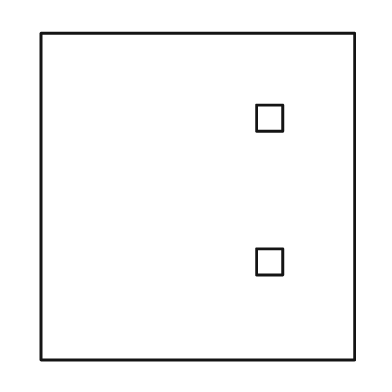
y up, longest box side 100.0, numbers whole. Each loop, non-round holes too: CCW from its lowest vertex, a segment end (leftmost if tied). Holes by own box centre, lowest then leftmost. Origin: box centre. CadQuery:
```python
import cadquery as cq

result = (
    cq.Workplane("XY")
    .moveTo(-48.0, -50.0)
    .lineTo(48.0, -50.0)
    .lineTo(48.0, 50.0)
    .lineTo(-48.0, 50.0)
    .close()
    .moveTo(18.0, -24.0)
    .lineTo(26.0, -24.0)
    .lineTo(26.0, -16.0)
    .lineTo(18.0, -16.0)
    .close()
    .moveTo(18.0, 20.0)
    .lineTo(26.0, 20.0)
    .lineTo(26.0, 28.0)
    .lineTo(18.0, 28.0)
    .close()
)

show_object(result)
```